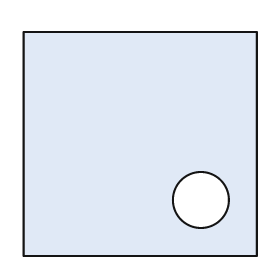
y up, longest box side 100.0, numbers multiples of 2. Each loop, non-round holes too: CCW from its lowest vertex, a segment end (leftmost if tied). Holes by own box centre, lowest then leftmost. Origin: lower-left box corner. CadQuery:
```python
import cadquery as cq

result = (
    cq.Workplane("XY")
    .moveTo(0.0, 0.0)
    .lineTo(100.0, 0.0)
    .lineTo(100.0, 96.0)
    .lineTo(0.0, 96.0)
    .close()
    .moveTo(76.0, 24.0)
    .circle(12.0)
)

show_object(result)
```